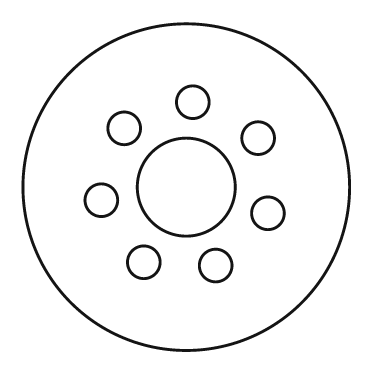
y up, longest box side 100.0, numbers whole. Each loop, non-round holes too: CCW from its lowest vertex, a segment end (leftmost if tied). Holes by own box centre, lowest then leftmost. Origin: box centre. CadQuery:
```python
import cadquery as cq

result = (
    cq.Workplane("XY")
    .moveTo(0.0, 0.0)
    .circle(50.0)
    .moveTo(9.0, -24.0)
    .circle(5.0)
    .moveTo(-13.0, -23.0)
    .circle(5.0)
    .moveTo(25.0, -8.0)
    .circle(5.0)
    .moveTo(-26.0, -4.0)
    .circle(5.0)
    .moveTo(0.0, 0.0)
    .circle(15.0)
    .moveTo(22.0, 15.0)
    .circle(5.0)
    .moveTo(-19.0, 18.0)
    .circle(5.0)
    .moveTo(2.0, 26.0)
    .circle(5.0)
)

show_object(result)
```